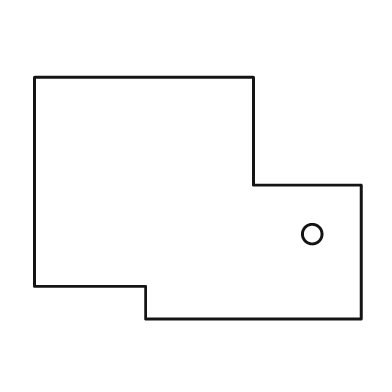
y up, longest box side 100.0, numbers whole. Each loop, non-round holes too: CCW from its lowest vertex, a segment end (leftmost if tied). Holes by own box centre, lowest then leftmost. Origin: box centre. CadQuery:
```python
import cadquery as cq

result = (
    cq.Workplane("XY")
    .moveTo(-16.0, -37.0)
    .lineTo(50.0, -37.0)
    .lineTo(50.0, 4.0)
    .lineTo(17.0, 4.0)
    .lineTo(17.0, 37.0)
    .lineTo(-50.0, 37.0)
    .lineTo(-50.0, -27.0)
    .lineTo(-16.0, -27.0)
    .close()
    .moveTo(35.0, -11.0)
    .circle(3.0)
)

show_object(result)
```